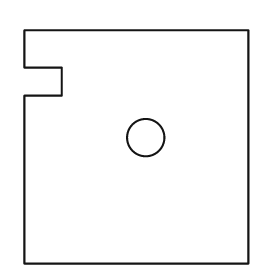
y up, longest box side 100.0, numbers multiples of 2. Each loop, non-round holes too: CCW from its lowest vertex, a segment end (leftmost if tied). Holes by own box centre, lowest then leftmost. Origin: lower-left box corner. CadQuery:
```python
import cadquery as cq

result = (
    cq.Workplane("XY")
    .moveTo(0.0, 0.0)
    .lineTo(96.0, 0.0)
    .lineTo(96.0, 100.0)
    .lineTo(0.0, 100.0)
    .lineTo(0.0, 84.0)
    .lineTo(16.0, 84.0)
    .lineTo(16.0, 72.0)
    .lineTo(0.0, 72.0)
    .close()
    .moveTo(52.0, 54.0)
    .circle(8.0)
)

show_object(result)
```